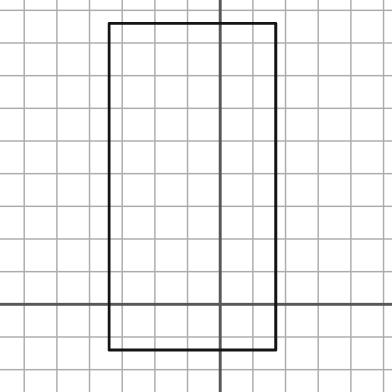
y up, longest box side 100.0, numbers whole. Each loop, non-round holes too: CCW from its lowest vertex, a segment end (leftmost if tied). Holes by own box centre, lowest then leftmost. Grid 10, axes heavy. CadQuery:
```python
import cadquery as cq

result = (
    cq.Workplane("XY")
    .moveTo(-34.0, -14.0)
    .lineTo(17.0, -14.0)
    .lineTo(17.0, 86.0)
    .lineTo(-34.0, 86.0)
    .close()
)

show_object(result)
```